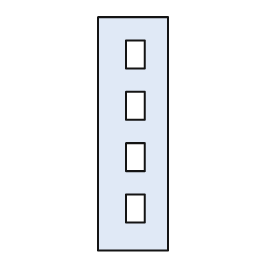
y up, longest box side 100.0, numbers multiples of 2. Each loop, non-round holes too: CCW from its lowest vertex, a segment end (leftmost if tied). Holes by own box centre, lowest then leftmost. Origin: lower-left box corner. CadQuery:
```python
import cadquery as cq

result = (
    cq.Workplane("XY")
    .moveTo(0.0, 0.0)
    .lineTo(30.0, 0.0)
    .lineTo(30.0, 100.0)
    .lineTo(0.0, 100.0)
    .close()
    .moveTo(12.0, 12.0)
    .lineTo(20.0, 12.0)
    .lineTo(20.0, 24.0)
    .lineTo(12.0, 24.0)
    .close()
    .moveTo(12.0, 34.0)
    .lineTo(20.0, 34.0)
    .lineTo(20.0, 46.0)
    .lineTo(12.0, 46.0)
    .close()
    .moveTo(12.0, 56.0)
    .lineTo(20.0, 56.0)
    .lineTo(20.0, 68.0)
    .lineTo(12.0, 68.0)
    .close()
    .moveTo(12.0, 78.0)
    .lineTo(20.0, 78.0)
    .lineTo(20.0, 90.0)
    .lineTo(12.0, 90.0)
    .close()
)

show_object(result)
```